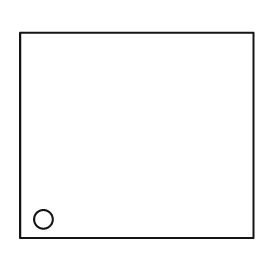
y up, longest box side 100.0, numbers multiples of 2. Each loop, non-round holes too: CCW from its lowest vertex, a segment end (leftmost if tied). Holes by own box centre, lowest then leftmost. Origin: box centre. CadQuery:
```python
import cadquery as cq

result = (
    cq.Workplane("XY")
    .moveTo(-50.0, -44.0)
    .lineTo(50.0, -44.0)
    .lineTo(50.0, 44.0)
    .lineTo(-50.0, 44.0)
    .close()
    .moveTo(-40.0, -36.0)
    .circle(4.0)
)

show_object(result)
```